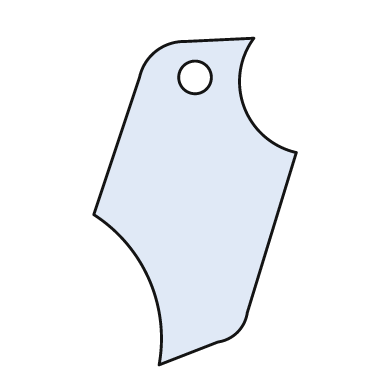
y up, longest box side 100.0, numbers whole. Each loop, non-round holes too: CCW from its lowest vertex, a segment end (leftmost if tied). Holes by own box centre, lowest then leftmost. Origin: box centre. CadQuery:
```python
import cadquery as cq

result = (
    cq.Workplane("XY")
    .moveTo(-11.0, -50.0)
    .lineTo(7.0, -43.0)
    .threePointArc((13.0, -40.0), (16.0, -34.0))
    .lineTo(31.0, 15.0)
    .threePointArc((15.0, 29.0), (18.0, 50.0))
    .lineTo(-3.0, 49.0)
    .threePointArc((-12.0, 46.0), (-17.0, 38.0))
    .lineTo(-31.0, -4.0)
    .threePointArc((-14.0, -24.0), (-11.0, -50.0))
    .close()
    .moveTo(0.0, 38.0)
    .circle(5.0)
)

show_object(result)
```